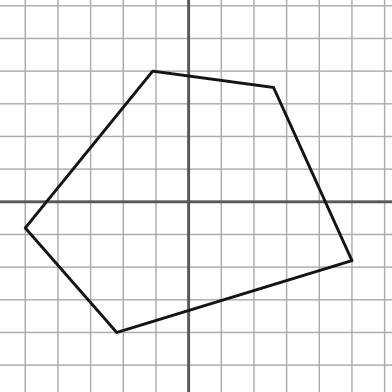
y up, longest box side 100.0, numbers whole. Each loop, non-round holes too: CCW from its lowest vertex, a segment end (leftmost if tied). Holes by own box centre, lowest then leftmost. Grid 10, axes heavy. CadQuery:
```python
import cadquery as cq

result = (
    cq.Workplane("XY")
    .moveTo(-22.0, -40.0)
    .lineTo(50.0, -18.0)
    .lineTo(26.0, 35.0)
    .lineTo(-11.0, 40.0)
    .lineTo(-50.0, -8.0)
    .close()
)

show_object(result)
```